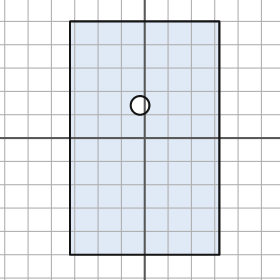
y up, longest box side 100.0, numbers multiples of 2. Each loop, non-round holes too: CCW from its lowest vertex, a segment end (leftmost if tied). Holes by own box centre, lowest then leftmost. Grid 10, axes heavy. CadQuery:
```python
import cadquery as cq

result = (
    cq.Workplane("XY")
    .moveTo(-32.0, -50.0)
    .lineTo(32.0, -50.0)
    .lineTo(32.0, 50.0)
    .lineTo(-32.0, 50.0)
    .close()
    .moveTo(-2.0, 14.0)
    .circle(4.0)
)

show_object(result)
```